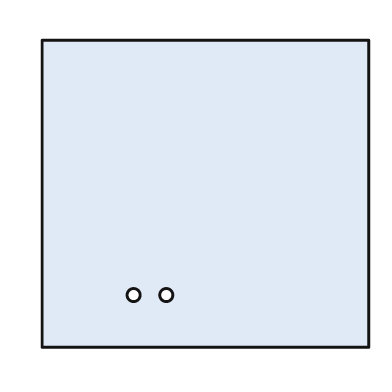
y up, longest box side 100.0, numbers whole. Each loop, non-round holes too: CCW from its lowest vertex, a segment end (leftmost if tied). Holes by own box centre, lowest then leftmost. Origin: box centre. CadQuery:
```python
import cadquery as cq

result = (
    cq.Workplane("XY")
    .moveTo(-50.0, -47.0)
    .lineTo(50.0, -47.0)
    .lineTo(50.0, 47.0)
    .lineTo(-50.0, 47.0)
    .close()
    .moveTo(-22.0, -31.0)
    .circle(2.0)
    .moveTo(-12.0, -31.0)
    .circle(2.0)
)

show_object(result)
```